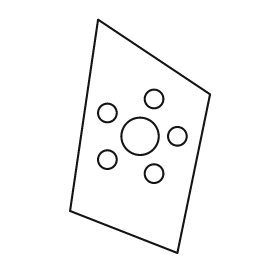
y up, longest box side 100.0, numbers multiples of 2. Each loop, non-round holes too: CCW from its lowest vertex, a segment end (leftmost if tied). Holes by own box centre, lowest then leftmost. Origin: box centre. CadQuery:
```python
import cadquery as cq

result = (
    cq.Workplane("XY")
    .moveTo(16.0, -50.0)
    .lineTo(30.0, 18.0)
    .lineTo(-18.0, 50.0)
    .lineTo(-30.0, -32.0)
    .close()
    .moveTo(6.0, -16.0)
    .circle(4.0)
    .moveTo(-14.0, -10.0)
    .circle(4.0)
    .moveTo(0.0, 0.0)
    .circle(8.0)
    .moveTo(16.0, 0.0)
    .circle(4.0)
    .moveTo(-14.0, 10.0)
    .circle(4.0)
    .moveTo(6.0, 16.0)
    .circle(4.0)
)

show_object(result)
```